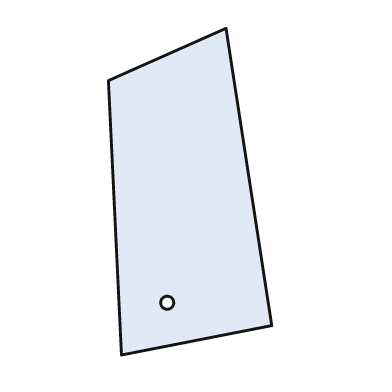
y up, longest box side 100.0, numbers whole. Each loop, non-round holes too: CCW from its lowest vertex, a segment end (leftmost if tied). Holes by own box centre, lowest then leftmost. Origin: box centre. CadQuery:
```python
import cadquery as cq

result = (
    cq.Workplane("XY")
    .moveTo(-21.0, -50.0)
    .lineTo(25.0, -41.0)
    .lineTo(11.0, 50.0)
    .lineTo(-25.0, 34.0)
    .close()
    .moveTo(-7.0, -34.0)
    .circle(2.0)
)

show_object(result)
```